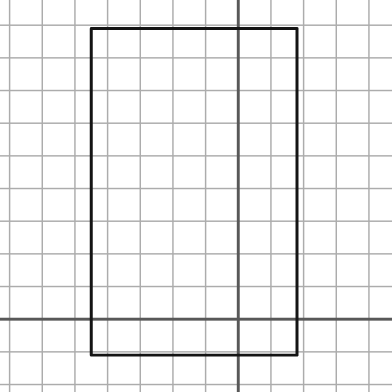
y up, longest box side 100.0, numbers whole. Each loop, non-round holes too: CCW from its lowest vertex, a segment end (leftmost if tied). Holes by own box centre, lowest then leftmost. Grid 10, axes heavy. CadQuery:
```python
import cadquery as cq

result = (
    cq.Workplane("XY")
    .moveTo(-45.0, -11.0)
    .lineTo(18.0, -11.0)
    .lineTo(18.0, 89.0)
    .lineTo(-45.0, 89.0)
    .close()
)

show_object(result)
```